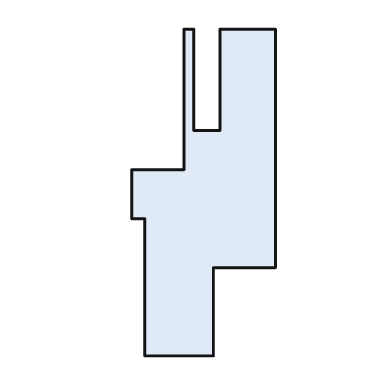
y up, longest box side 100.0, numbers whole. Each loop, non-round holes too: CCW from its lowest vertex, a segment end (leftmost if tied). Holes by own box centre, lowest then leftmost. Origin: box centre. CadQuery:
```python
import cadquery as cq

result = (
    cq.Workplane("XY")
    .moveTo(-18.0, -50.0)
    .lineTo(3.0, -50.0)
    .lineTo(3.0, -23.0)
    .lineTo(22.0, -23.0)
    .lineTo(22.0, 50.0)
    .lineTo(5.0, 50.0)
    .lineTo(5.0, 19.0)
    .lineTo(-3.0, 19.0)
    .lineTo(-3.0, 50.0)
    .lineTo(-6.0, 50.0)
    .lineTo(-6.0, 7.0)
    .lineTo(-22.0, 7.0)
    .lineTo(-22.0, -8.0)
    .lineTo(-18.0, -8.0)
    .close()
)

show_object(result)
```